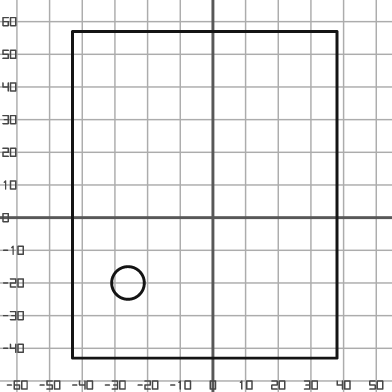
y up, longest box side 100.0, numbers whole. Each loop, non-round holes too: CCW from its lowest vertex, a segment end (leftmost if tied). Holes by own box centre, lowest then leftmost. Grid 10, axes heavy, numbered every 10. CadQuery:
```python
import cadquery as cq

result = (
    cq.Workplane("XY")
    .moveTo(-43.0, -43.0)
    .lineTo(38.0, -43.0)
    .lineTo(38.0, 57.0)
    .lineTo(-43.0, 57.0)
    .close()
    .moveTo(-26.0, -20.0)
    .circle(5.0)
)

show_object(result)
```